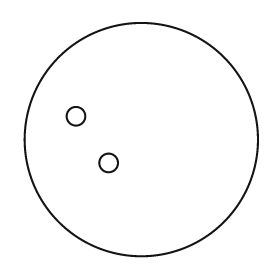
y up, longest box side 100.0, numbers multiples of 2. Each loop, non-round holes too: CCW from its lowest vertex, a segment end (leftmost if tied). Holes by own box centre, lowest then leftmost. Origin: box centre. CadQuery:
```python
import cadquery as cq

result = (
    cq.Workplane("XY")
    .moveTo(0.0, 0.0)
    .circle(50.0)
    .moveTo(-14.0, -10.0)
    .circle(4.0)
    .moveTo(-28.0, 10.0)
    .circle(4.0)
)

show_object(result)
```